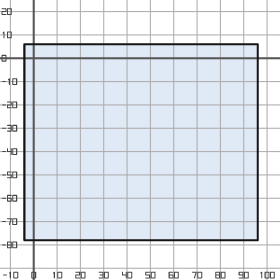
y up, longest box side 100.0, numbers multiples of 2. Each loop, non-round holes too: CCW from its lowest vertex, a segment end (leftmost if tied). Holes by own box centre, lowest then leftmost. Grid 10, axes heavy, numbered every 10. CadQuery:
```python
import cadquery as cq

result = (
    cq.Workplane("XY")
    .moveTo(-4.0, -78.0)
    .lineTo(96.0, -78.0)
    .lineTo(96.0, 6.0)
    .lineTo(-4.0, 6.0)
    .close()
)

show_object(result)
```